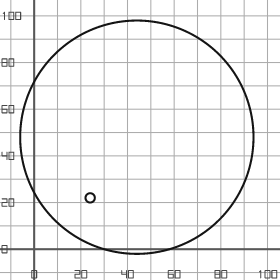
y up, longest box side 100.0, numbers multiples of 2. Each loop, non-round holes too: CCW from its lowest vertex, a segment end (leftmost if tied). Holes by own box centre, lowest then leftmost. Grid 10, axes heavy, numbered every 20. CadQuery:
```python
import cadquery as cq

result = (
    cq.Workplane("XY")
    .moveTo(44.0, 48.0)
    .circle(50.0)
    .moveTo(24.0, 22.0)
    .circle(2.0)
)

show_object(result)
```